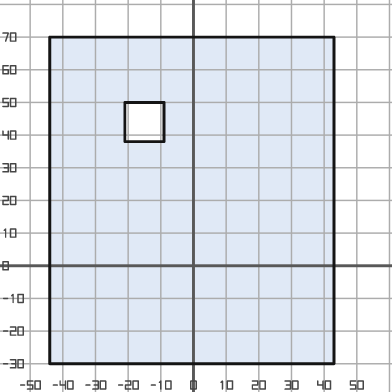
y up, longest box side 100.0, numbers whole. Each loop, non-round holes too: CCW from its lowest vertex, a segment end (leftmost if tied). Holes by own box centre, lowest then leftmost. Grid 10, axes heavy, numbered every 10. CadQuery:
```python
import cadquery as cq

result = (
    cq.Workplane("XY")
    .moveTo(-44.0, -30.0)
    .lineTo(43.0, -30.0)
    .lineTo(43.0, 70.0)
    .lineTo(-44.0, 70.0)
    .close()
    .moveTo(-21.0, 38.0)
    .lineTo(-9.0, 38.0)
    .lineTo(-9.0, 50.0)
    .lineTo(-21.0, 50.0)
    .close()
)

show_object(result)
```